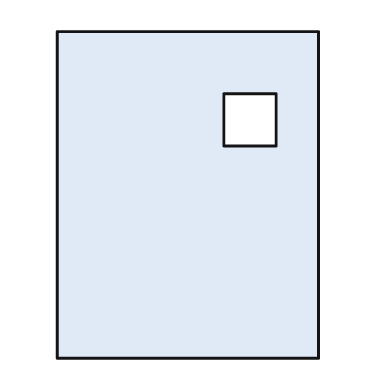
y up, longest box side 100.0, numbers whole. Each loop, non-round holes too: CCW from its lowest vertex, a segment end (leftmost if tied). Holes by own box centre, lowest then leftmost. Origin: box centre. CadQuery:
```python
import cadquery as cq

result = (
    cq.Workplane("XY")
    .moveTo(-40.0, -50.0)
    .lineTo(40.0, -50.0)
    .lineTo(40.0, 50.0)
    .lineTo(-40.0, 50.0)
    .close()
    .moveTo(11.0, 15.0)
    .lineTo(27.0, 15.0)
    .lineTo(27.0, 31.0)
    .lineTo(11.0, 31.0)
    .close()
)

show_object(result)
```